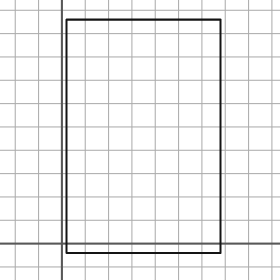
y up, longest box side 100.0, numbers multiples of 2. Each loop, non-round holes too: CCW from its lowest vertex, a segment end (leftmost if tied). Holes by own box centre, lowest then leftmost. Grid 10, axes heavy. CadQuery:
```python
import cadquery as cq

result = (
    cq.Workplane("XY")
    .moveTo(2.0, -4.0)
    .lineTo(68.0, -4.0)
    .lineTo(68.0, 96.0)
    .lineTo(2.0, 96.0)
    .close()
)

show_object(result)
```